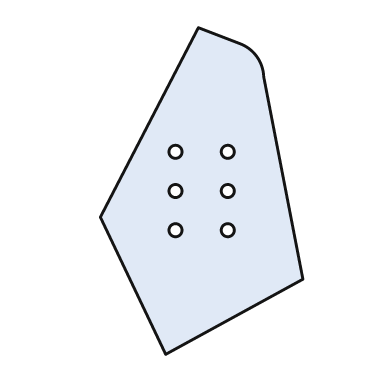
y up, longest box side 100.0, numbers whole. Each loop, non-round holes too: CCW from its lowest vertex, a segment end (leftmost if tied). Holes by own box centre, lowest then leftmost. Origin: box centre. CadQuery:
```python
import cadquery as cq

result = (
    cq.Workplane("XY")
    .moveTo(-11.0, -50.0)
    .lineTo(31.0, -27.0)
    .lineTo(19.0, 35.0)
    .threePointArc((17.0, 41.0), (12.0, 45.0))
    .lineTo(-1.0, 50.0)
    .lineTo(-31.0, -8.0)
    .close()
    .moveTo(-8.0, -12.0)
    .circle(2.0)
    .moveTo(8.0, -12.0)
    .circle(2.0)
    .moveTo(-8.0, 0.0)
    .circle(2.0)
    .moveTo(8.0, 0.0)
    .circle(2.0)
    .moveTo(-8.0, 12.0)
    .circle(2.0)
    .moveTo(8.0, 12.0)
    .circle(2.0)
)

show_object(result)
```